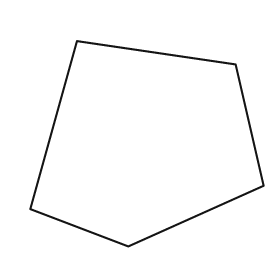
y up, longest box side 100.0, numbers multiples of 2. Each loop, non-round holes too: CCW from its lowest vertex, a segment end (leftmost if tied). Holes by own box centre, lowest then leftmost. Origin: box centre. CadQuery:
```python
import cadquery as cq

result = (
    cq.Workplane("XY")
    .moveTo(-8.0, -44.0)
    .lineTo(50.0, -18.0)
    .lineTo(38.0, 34.0)
    .lineTo(-30.0, 44.0)
    .lineTo(-50.0, -28.0)
    .close()
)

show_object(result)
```